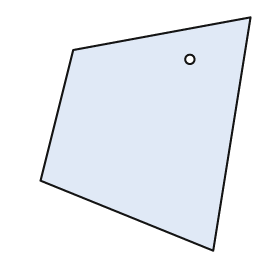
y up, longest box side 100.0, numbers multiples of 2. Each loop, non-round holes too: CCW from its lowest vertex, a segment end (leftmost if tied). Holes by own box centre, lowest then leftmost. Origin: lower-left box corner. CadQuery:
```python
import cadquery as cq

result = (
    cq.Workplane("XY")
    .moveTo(74.0, 0.0)
    .lineTo(90.0, 100.0)
    .lineTo(14.0, 86.0)
    .lineTo(0.0, 30.0)
    .close()
    .moveTo(64.0, 82.0)
    .circle(2.0)
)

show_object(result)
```